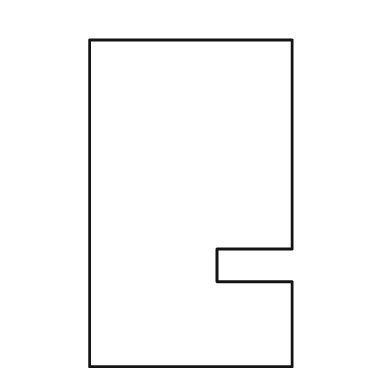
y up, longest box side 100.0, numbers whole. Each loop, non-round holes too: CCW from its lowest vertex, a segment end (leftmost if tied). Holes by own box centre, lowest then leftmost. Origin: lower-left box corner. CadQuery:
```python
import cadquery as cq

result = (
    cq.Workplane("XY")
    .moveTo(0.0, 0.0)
    .lineTo(62.0, 0.0)
    .lineTo(62.0, 26.0)
    .lineTo(39.0, 26.0)
    .lineTo(39.0, 36.0)
    .lineTo(62.0, 36.0)
    .lineTo(62.0, 100.0)
    .lineTo(0.0, 100.0)
    .close()
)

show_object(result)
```